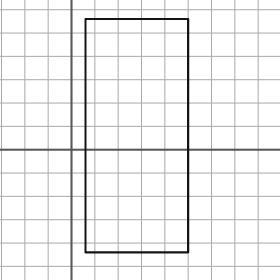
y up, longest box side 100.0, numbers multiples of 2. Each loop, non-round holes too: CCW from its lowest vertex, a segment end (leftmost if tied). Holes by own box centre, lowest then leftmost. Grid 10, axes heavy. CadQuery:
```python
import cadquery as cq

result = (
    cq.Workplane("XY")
    .moveTo(6.0, -44.0)
    .lineTo(50.0, -44.0)
    .lineTo(50.0, 56.0)
    .lineTo(6.0, 56.0)
    .close()
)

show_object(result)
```